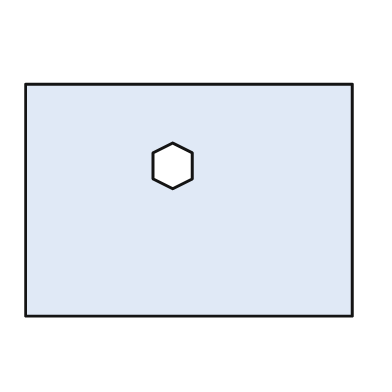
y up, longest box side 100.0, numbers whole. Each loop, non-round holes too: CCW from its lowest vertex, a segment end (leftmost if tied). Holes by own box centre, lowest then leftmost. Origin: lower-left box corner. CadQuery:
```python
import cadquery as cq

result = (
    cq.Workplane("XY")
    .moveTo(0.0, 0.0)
    .lineTo(100.0, 0.0)
    .lineTo(100.0, 71.0)
    .lineTo(0.0, 71.0)
    .close()
    .moveTo(45.0, 39.0)
    .lineTo(51.0, 42.0)
    .lineTo(51.0, 50.0)
    .lineTo(45.0, 53.0)
    .lineTo(39.0, 50.0)
    .lineTo(39.0, 42.0)
    .close()
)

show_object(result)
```